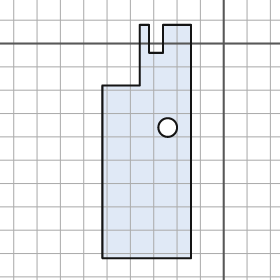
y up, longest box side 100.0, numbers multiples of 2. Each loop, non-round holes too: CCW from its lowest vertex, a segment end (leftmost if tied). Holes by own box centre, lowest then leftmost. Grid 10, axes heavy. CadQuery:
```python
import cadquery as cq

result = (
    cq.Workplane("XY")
    .moveTo(-52.0, -92.0)
    .lineTo(-14.0, -92.0)
    .lineTo(-14.0, 8.0)
    .lineTo(-26.0, 8.0)
    .lineTo(-26.0, -4.0)
    .lineTo(-32.0, -4.0)
    .lineTo(-32.0, 8.0)
    .lineTo(-36.0, 8.0)
    .lineTo(-36.0, -18.0)
    .lineTo(-52.0, -18.0)
    .close()
    .moveTo(-24.0, -36.0)
    .circle(4.0)
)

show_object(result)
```